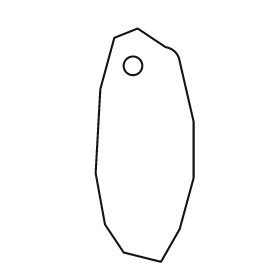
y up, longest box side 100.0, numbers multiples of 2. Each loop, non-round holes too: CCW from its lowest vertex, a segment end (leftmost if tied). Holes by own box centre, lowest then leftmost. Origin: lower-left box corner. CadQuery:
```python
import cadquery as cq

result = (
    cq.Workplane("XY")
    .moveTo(28.0, 0.0)
    .lineTo(36.0, 14.0)
    .lineTo(42.0, 36.0)
    .lineTo(42.0, 60.0)
    .lineTo(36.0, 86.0)
    .threePointArc((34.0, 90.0), (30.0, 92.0))
    .lineTo(18.0, 100.0)
    .lineTo(8.0, 96.0)
    .lineTo(2.0, 74.0)
    .lineTo(0.0, 38.0)
    .lineTo(4.0, 16.0)
    .lineTo(12.0, 4.0)
    .close()
    .moveTo(16.0, 84.0)
    .circle(4.0)
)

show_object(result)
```